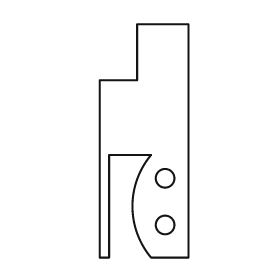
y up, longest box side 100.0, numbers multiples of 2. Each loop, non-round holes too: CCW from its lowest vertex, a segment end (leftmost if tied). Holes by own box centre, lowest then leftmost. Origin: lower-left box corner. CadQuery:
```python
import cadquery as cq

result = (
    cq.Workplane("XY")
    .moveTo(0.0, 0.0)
    .lineTo(4.0, 0.0)
    .lineTo(4.0, 44.0)
    .lineTo(22.0, 44.0)
    .threePointArc((14.0, 22.0), (22.0, 0.0))
    .lineTo(38.0, 0.0)
    .lineTo(38.0, 100.0)
    .lineTo(16.0, 100.0)
    .lineTo(16.0, 76.0)
    .lineTo(0.0, 76.0)
    .close()
    .moveTo(28.0, 14.0)
    .circle(4.0)
    .moveTo(28.0, 34.0)
    .circle(4.0)
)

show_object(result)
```